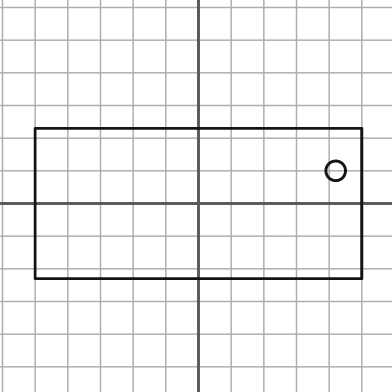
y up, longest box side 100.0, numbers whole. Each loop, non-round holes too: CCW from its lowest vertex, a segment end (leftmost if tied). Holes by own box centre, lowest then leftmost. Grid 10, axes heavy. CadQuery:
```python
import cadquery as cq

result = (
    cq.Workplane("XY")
    .moveTo(-50.0, -23.0)
    .lineTo(50.0, -23.0)
    .lineTo(50.0, 23.0)
    .lineTo(-50.0, 23.0)
    .close()
    .moveTo(42.0, 10.0)
    .circle(3.0)
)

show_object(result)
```